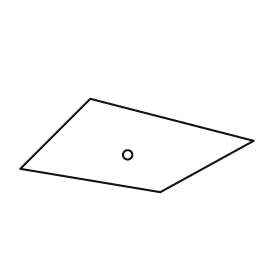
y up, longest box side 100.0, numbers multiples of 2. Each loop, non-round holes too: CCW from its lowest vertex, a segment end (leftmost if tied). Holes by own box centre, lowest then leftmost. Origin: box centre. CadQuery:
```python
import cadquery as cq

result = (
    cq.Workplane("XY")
    .moveTo(10.0, -20.0)
    .lineTo(50.0, 2.0)
    .lineTo(-20.0, 20.0)
    .lineTo(-50.0, -10.0)
    .close()
    .moveTo(-4.0, -4.0)
    .circle(2.0)
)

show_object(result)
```